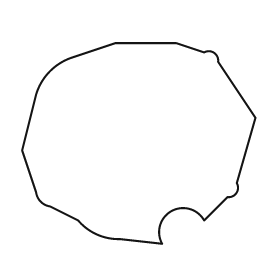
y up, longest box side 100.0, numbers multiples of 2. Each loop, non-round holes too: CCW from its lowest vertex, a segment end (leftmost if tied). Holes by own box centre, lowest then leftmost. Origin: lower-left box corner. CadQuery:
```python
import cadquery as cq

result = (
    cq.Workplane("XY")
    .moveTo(60.0, 0.0)
    .threePointArc((64.0, 14.0), (78.0, 10.0))
    .lineTo(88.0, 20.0)
    .threePointArc((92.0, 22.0), (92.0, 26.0))
    .lineTo(100.0, 54.0)
    .lineTo(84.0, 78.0)
    .threePointArc((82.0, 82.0), (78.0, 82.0))
    .lineTo(66.0, 86.0)
    .lineTo(40.0, 86.0)
    .lineTo(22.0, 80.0)
    .threePointArc((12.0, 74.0), (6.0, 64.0))
    .lineTo(0.0, 40.0)
    .lineTo(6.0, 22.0)
    .threePointArc((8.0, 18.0), (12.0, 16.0))
    .lineTo(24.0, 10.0)
    .threePointArc((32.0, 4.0), (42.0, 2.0))
    .close()
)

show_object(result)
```